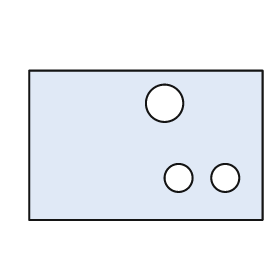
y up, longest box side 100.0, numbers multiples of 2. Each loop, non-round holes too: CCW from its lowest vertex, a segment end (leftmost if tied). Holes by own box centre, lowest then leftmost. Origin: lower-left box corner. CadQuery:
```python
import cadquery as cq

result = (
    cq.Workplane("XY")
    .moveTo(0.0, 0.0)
    .lineTo(100.0, 0.0)
    .lineTo(100.0, 64.0)
    .lineTo(0.0, 64.0)
    .close()
    .moveTo(64.0, 18.0)
    .circle(6.0)
    .moveTo(84.0, 18.0)
    .circle(6.0)
    .moveTo(58.0, 50.0)
    .circle(8.0)
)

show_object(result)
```